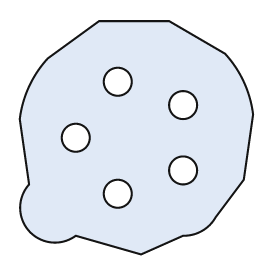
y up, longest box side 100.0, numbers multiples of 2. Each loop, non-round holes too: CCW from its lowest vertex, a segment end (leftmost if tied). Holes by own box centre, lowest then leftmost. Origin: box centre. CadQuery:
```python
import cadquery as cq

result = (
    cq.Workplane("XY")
    .moveTo(2.0, -50.0)
    .lineTo(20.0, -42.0)
    .threePointArc((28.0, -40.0), (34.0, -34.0))
    .lineTo(46.0, -18.0)
    .lineTo(50.0, 10.0)
    .threePointArc((46.0, 24.0), (38.0, 36.0))
    .lineTo(14.0, 50.0)
    .lineTo(-16.0, 50.0)
    .lineTo(-38.0, 34.0)
    .threePointArc((-46.0, 22.0), (-50.0, 8.0))
    .lineTo(-46.0, -20.0)
    .threePointArc((-46.0, -40.0), (-26.0, -42.0))
    .close()
    .moveTo(-8.0, -24.0)
    .circle(6.0)
    .moveTo(20.0, -14.0)
    .circle(6.0)
    .moveTo(-26.0, 0.0)
    .circle(6.0)
    .moveTo(20.0, 14.0)
    .circle(6.0)
    .moveTo(-8.0, 24.0)
    .circle(6.0)
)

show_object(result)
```